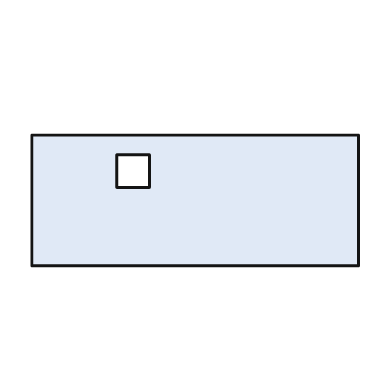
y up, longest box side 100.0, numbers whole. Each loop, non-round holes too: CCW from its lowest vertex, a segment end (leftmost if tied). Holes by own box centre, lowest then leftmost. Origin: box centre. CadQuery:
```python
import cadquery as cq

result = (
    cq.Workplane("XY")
    .moveTo(-50.0, -20.0)
    .lineTo(50.0, -20.0)
    .lineTo(50.0, 20.0)
    .lineTo(-50.0, 20.0)
    .close()
    .moveTo(-24.0, 4.0)
    .lineTo(-14.0, 4.0)
    .lineTo(-14.0, 14.0)
    .lineTo(-24.0, 14.0)
    .close()
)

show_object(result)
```